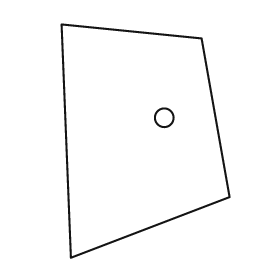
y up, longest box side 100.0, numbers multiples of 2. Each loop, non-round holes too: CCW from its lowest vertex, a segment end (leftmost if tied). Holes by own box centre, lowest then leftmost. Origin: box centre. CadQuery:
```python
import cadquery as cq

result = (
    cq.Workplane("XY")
    .moveTo(-32.0, -50.0)
    .lineTo(36.0, -24.0)
    .lineTo(24.0, 44.0)
    .lineTo(-36.0, 50.0)
    .close()
    .moveTo(8.0, 10.0)
    .circle(4.0)
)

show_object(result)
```